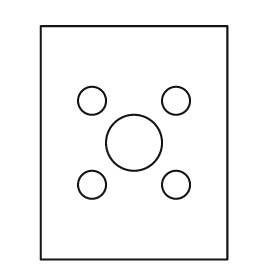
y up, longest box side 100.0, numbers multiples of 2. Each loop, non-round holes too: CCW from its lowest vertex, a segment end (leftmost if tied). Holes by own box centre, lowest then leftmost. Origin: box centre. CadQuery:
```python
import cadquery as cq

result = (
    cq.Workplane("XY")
    .moveTo(-40.0, -50.0)
    .lineTo(40.0, -50.0)
    .lineTo(40.0, 50.0)
    .lineTo(-40.0, 50.0)
    .close()
    .moveTo(-18.0, -18.0)
    .circle(6.0)
    .moveTo(18.0, -18.0)
    .circle(6.0)
    .moveTo(0.0, 0.0)
    .circle(12.0)
    .moveTo(-18.0, 18.0)
    .circle(6.0)
    .moveTo(18.0, 18.0)
    .circle(6.0)
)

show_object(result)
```